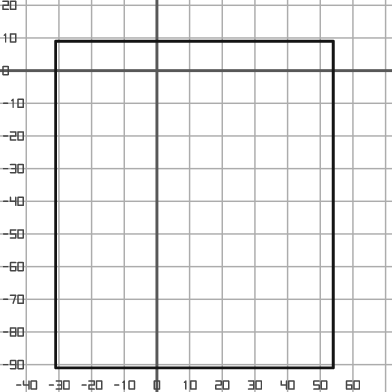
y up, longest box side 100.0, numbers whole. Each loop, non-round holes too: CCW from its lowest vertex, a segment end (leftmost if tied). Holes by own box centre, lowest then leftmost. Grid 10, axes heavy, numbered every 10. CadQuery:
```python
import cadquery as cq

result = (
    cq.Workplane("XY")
    .moveTo(-31.0, -91.0)
    .lineTo(54.0, -91.0)
    .lineTo(54.0, 9.0)
    .lineTo(-31.0, 9.0)
    .close()
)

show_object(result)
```